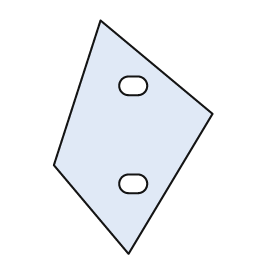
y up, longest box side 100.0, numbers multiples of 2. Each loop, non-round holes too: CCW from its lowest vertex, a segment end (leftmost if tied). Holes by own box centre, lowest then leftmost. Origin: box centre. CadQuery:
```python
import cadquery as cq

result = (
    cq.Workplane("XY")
    .moveTo(-2.0, -50.0)
    .lineTo(34.0, 10.0)
    .lineTo(-14.0, 50.0)
    .lineTo(-34.0, -12.0)
    .close()
    .moveTo(-2.0, -24.0)
    .lineTo(2.0, -24.0)
    .threePointArc((6.0, -20.0), (2.0, -16.0))
    .lineTo(-2.0, -16.0)
    .threePointArc((-6.0, -20.0), (-2.0, -24.0))
    .close()
    .moveTo(-2.0, 18.0)
    .lineTo(2.0, 18.0)
    .threePointArc((6.0, 22.0), (2.0, 26.0))
    .lineTo(-2.0, 26.0)
    .threePointArc((-6.0, 22.0), (-2.0, 18.0))
    .close()
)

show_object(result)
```